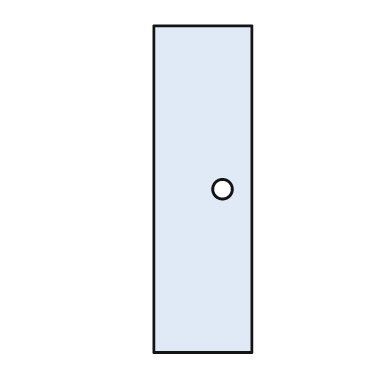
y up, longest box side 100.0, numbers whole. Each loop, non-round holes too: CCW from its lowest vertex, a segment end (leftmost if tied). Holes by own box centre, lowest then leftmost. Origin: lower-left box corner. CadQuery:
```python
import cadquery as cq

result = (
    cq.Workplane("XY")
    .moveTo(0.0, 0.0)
    .lineTo(30.0, 0.0)
    .lineTo(30.0, 100.0)
    .lineTo(0.0, 100.0)
    .close()
    .moveTo(21.0, 50.0)
    .circle(3.0)
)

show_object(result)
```